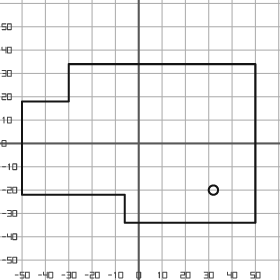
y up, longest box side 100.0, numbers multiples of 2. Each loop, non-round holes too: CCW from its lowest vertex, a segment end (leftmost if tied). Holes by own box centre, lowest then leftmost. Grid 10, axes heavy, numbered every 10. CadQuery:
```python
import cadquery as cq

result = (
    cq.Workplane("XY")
    .moveTo(-6.0, -34.0)
    .lineTo(50.0, -34.0)
    .lineTo(50.0, 34.0)
    .lineTo(-30.0, 34.0)
    .lineTo(-30.0, 18.0)
    .lineTo(-50.0, 18.0)
    .lineTo(-50.0, -22.0)
    .lineTo(-6.0, -22.0)
    .close()
    .moveTo(32.0, -20.0)
    .circle(2.0)
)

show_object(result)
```